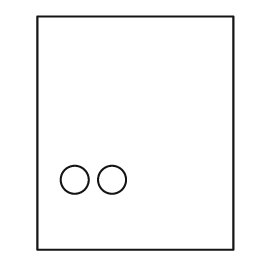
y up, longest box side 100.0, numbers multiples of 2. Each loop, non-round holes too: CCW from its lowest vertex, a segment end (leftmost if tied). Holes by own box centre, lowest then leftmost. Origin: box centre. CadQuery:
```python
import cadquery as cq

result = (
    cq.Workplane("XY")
    .moveTo(-42.0, -50.0)
    .lineTo(42.0, -50.0)
    .lineTo(42.0, 50.0)
    .lineTo(-42.0, 50.0)
    .close()
    .moveTo(-26.0, -20.0)
    .circle(6.0)
    .moveTo(-10.0, -20.0)
    .circle(6.0)
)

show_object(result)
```